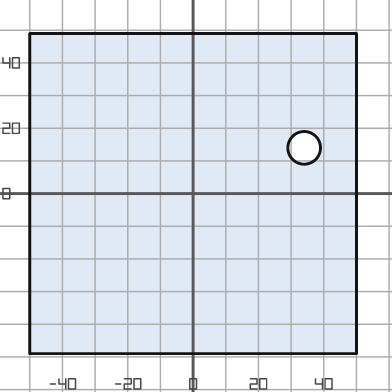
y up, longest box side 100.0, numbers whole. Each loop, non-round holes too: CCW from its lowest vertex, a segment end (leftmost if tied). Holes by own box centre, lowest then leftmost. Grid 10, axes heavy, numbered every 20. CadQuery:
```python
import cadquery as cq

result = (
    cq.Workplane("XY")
    .moveTo(-50.0, -49.0)
    .lineTo(50.0, -49.0)
    .lineTo(50.0, 49.0)
    .lineTo(-50.0, 49.0)
    .close()
    .moveTo(34.0, 14.0)
    .circle(5.0)
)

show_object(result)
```